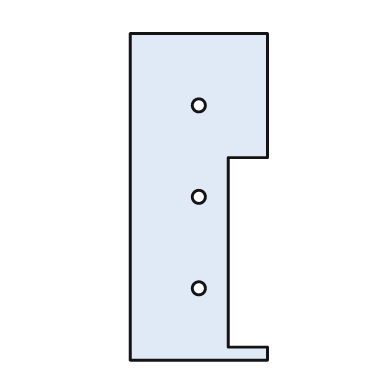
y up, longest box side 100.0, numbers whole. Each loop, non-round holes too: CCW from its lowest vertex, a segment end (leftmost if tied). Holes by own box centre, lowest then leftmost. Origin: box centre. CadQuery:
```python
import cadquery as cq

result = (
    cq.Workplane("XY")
    .moveTo(-21.0, -50.0)
    .lineTo(21.0, -50.0)
    .lineTo(21.0, -46.0)
    .lineTo(9.0, -46.0)
    .lineTo(9.0, 12.0)
    .lineTo(21.0, 12.0)
    .lineTo(21.0, 50.0)
    .lineTo(-21.0, 50.0)
    .close()
    .moveTo(0.0, -28.0)
    .circle(2.0)
    .moveTo(0.0, 0.0)
    .circle(2.0)
    .moveTo(0.0, 28.0)
    .circle(2.0)
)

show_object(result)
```